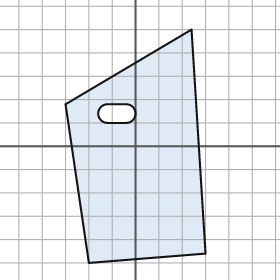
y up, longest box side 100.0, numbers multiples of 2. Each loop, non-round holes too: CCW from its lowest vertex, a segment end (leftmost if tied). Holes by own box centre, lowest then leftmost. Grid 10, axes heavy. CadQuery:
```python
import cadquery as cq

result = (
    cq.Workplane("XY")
    .moveTo(-20.0, -50.0)
    .lineTo(30.0, -46.0)
    .lineTo(24.0, 50.0)
    .lineTo(-30.0, 18.0)
    .close()
    .moveTo(-12.0, 10.0)
    .lineTo(-4.0, 10.0)
    .threePointArc((0.0, 14.0), (-4.0, 18.0))
    .lineTo(-12.0, 18.0)
    .threePointArc((-16.0, 14.0), (-12.0, 10.0))
    .close()
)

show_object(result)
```